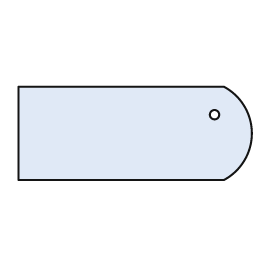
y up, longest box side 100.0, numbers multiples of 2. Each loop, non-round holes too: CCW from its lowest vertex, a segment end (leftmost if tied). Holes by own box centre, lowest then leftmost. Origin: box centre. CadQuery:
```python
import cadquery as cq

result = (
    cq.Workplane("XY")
    .moveTo(-50.0, -20.0)
    .lineTo(38.0, -20.0)
    .threePointArc((50.0, 0.0), (38.0, 20.0))
    .lineTo(-50.0, 20.0)
    .close()
    .moveTo(34.0, 8.0)
    .circle(2.0)
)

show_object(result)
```